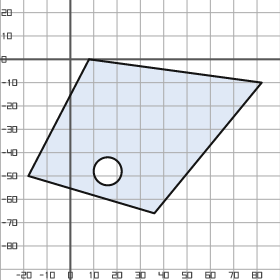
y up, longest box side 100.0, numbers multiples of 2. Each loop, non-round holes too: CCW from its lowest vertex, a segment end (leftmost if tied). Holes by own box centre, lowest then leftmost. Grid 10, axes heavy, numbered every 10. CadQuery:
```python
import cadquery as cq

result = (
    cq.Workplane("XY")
    .moveTo(36.0, -66.0)
    .lineTo(82.0, -10.0)
    .lineTo(8.0, 0.0)
    .lineTo(-18.0, -50.0)
    .close()
    .moveTo(16.0, -48.0)
    .circle(6.0)
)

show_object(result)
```